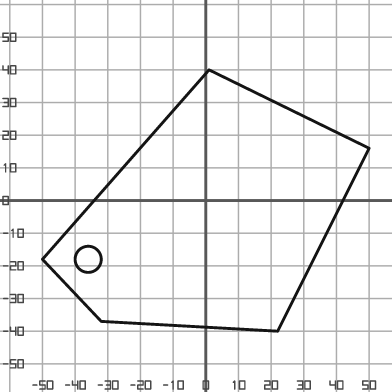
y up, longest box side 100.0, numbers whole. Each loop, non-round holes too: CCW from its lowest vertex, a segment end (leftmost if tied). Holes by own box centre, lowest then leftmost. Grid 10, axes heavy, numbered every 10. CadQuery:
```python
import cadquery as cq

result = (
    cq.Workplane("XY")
    .moveTo(22.0, -40.0)
    .lineTo(50.0, 16.0)
    .lineTo(1.0, 40.0)
    .lineTo(-50.0, -18.0)
    .lineTo(-32.0, -37.0)
    .close()
    .moveTo(-36.0, -18.0)
    .circle(4.0)
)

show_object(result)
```